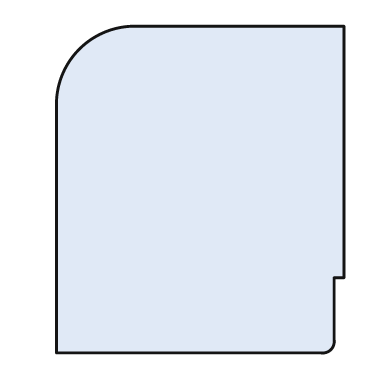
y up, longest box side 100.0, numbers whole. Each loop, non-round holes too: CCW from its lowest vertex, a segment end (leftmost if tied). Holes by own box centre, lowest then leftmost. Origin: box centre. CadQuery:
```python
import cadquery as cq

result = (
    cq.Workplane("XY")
    .moveTo(-44.0, -50.0)
    .lineTo(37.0, -50.0)
    .threePointArc((40.0, -49.0), (41.0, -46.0))
    .lineTo(41.0, -27.0)
    .lineTo(44.0, -27.0)
    .lineTo(44.0, 50.0)
    .lineTo(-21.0, 50.0)
    .threePointArc((-37.0, 43.0), (-44.0, 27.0))
    .close()
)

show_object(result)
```